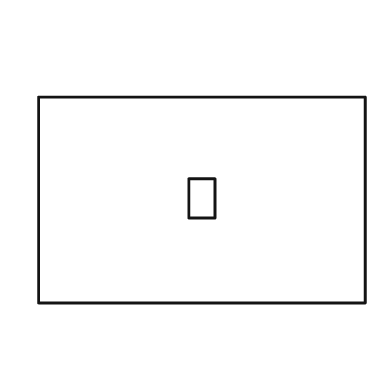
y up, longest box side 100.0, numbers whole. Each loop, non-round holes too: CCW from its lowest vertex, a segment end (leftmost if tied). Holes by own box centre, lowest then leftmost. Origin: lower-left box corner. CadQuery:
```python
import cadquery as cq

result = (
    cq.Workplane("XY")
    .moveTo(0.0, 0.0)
    .lineTo(100.0, 0.0)
    .lineTo(100.0, 63.0)
    .lineTo(0.0, 63.0)
    .close()
    .moveTo(46.0, 26.0)
    .lineTo(54.0, 26.0)
    .lineTo(54.0, 38.0)
    .lineTo(46.0, 38.0)
    .close()
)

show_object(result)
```